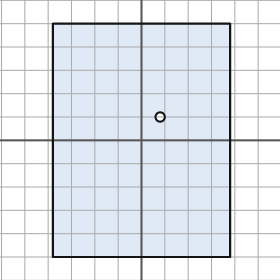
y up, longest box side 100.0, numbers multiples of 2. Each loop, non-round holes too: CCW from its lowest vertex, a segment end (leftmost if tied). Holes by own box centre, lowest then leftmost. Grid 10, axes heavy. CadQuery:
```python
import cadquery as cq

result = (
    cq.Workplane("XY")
    .moveTo(-38.0, -50.0)
    .lineTo(38.0, -50.0)
    .lineTo(38.0, 50.0)
    .lineTo(-38.0, 50.0)
    .close()
    .moveTo(8.0, 10.0)
    .circle(2.0)
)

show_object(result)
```